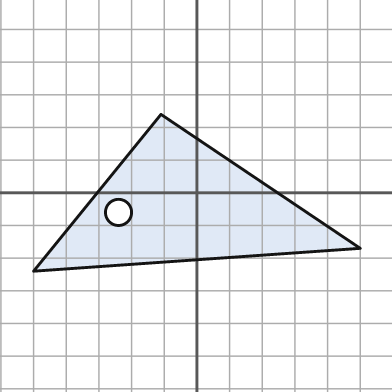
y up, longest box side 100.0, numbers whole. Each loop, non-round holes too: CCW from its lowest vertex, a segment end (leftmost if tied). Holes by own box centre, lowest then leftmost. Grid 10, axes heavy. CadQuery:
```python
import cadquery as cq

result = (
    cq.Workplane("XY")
    .moveTo(-50.0, -24.0)
    .lineTo(50.0, -17.0)
    .lineTo(-11.0, 24.0)
    .close()
    .moveTo(-24.0, -6.0)
    .circle(4.0)
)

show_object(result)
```